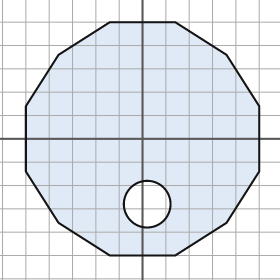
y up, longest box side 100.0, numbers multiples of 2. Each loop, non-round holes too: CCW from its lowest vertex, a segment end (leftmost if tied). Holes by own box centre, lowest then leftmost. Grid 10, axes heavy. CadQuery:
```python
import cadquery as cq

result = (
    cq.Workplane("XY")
    .moveTo(-14.0, -50.0)
    .lineTo(14.0, -50.0)
    .lineTo(36.0, -36.0)
    .lineTo(50.0, -14.0)
    .lineTo(50.0, 14.0)
    .lineTo(36.0, 36.0)
    .lineTo(14.0, 50.0)
    .lineTo(-14.0, 50.0)
    .lineTo(-36.0, 36.0)
    .lineTo(-50.0, 14.0)
    .lineTo(-50.0, -14.0)
    .lineTo(-36.0, -36.0)
    .close()
    .moveTo(2.0, -28.0)
    .circle(10.0)
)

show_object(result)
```